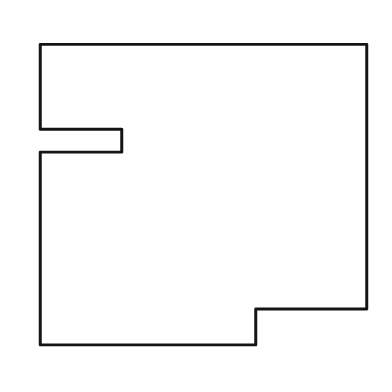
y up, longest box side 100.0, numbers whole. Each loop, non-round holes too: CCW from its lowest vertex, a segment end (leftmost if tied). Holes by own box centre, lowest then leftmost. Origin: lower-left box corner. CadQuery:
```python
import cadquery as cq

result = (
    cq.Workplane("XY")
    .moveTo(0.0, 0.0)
    .lineTo(66.0, 0.0)
    .lineTo(66.0, 11.0)
    .lineTo(100.0, 11.0)
    .lineTo(100.0, 92.0)
    .lineTo(0.0, 92.0)
    .lineTo(0.0, 66.0)
    .lineTo(25.0, 66.0)
    .lineTo(25.0, 59.0)
    .lineTo(0.0, 59.0)
    .close()
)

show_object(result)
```